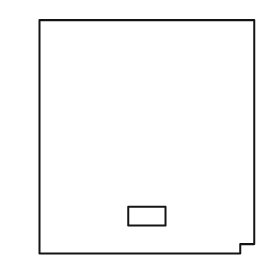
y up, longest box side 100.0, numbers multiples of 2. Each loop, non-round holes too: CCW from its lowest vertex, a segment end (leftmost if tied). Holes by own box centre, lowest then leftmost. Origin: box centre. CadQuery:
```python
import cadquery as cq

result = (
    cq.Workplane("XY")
    .moveTo(-46.0, -50.0)
    .lineTo(40.0, -50.0)
    .lineTo(40.0, -46.0)
    .lineTo(46.0, -46.0)
    .lineTo(46.0, 50.0)
    .lineTo(-46.0, 50.0)
    .close()
    .moveTo(-8.0, -38.0)
    .lineTo(8.0, -38.0)
    .lineTo(8.0, -30.0)
    .lineTo(-8.0, -30.0)
    .close()
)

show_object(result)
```